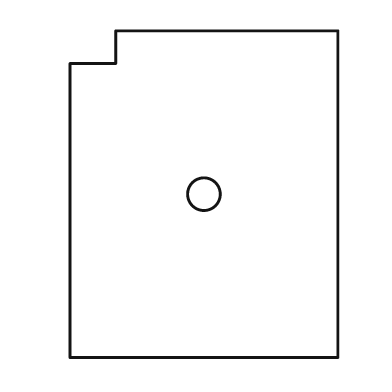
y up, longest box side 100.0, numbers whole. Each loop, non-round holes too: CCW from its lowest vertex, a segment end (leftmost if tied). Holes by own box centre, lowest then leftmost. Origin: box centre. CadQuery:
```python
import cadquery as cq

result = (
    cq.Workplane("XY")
    .moveTo(-41.0, -50.0)
    .lineTo(41.0, -50.0)
    .lineTo(41.0, 50.0)
    .lineTo(-27.0, 50.0)
    .lineTo(-27.0, 40.0)
    .lineTo(-41.0, 40.0)
    .close()
    .moveTo(0.0, 0.0)
    .circle(5.0)
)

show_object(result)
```